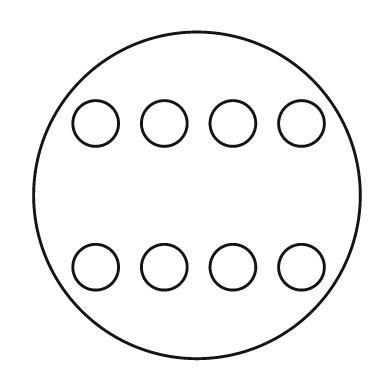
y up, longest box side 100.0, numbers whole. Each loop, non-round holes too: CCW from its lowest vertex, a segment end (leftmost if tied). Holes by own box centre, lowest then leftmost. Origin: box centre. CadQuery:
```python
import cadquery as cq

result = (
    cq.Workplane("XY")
    .moveTo(0.0, 0.0)
    .circle(50.0)
    .moveTo(-31.0, -22.0)
    .circle(7.0)
    .moveTo(-10.0, -22.0)
    .circle(7.0)
    .moveTo(11.0, -22.0)
    .circle(7.0)
    .moveTo(32.0, -22.0)
    .circle(7.0)
    .moveTo(-31.0, 22.0)
    .circle(7.0)
    .moveTo(-10.0, 22.0)
    .circle(7.0)
    .moveTo(11.0, 22.0)
    .circle(7.0)
    .moveTo(32.0, 22.0)
    .circle(7.0)
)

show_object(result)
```